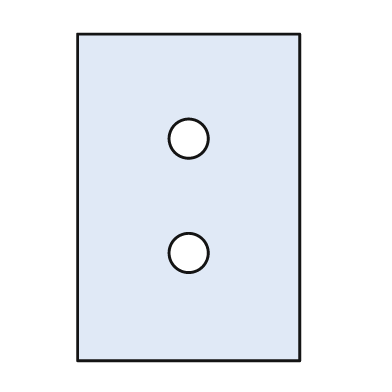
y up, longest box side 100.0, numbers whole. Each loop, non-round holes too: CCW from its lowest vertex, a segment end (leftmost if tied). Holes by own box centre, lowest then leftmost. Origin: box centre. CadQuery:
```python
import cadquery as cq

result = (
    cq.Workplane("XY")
    .moveTo(-34.0, -50.0)
    .lineTo(34.0, -50.0)
    .lineTo(34.0, 50.0)
    .lineTo(-34.0, 50.0)
    .close()
    .moveTo(0.0, -17.0)
    .circle(6.0)
    .moveTo(0.0, 18.0)
    .circle(6.0)
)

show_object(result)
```